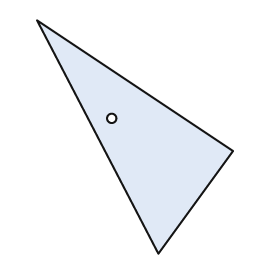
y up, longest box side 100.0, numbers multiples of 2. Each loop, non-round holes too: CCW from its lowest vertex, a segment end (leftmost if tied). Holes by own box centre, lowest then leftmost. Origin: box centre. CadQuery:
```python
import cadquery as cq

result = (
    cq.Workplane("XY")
    .moveTo(10.0, -50.0)
    .lineTo(42.0, -6.0)
    .lineTo(-42.0, 50.0)
    .close()
    .moveTo(-10.0, 8.0)
    .circle(2.0)
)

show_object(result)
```